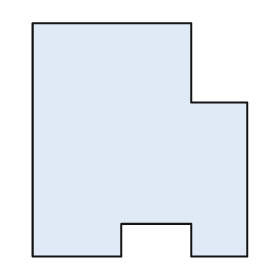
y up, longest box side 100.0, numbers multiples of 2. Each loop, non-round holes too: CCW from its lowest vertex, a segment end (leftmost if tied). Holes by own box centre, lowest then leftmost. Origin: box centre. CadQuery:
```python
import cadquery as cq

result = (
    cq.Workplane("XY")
    .moveTo(-46.0, -50.0)
    .lineTo(-8.0, -50.0)
    .lineTo(-8.0, -36.0)
    .lineTo(22.0, -36.0)
    .lineTo(22.0, -50.0)
    .lineTo(46.0, -50.0)
    .lineTo(46.0, 16.0)
    .lineTo(22.0, 16.0)
    .lineTo(22.0, 50.0)
    .lineTo(-46.0, 50.0)
    .close()
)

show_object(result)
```